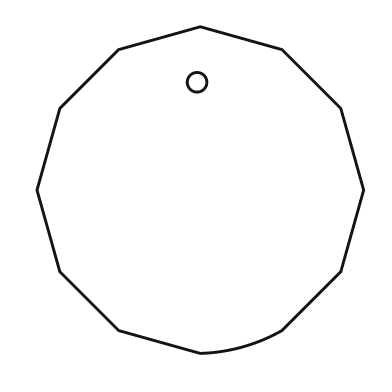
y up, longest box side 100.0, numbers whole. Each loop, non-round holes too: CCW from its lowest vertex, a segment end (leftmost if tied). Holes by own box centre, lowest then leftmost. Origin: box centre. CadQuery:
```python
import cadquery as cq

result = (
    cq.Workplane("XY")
    .moveTo(0.0, -50.0)
    .threePointArc((13.0, -48.0), (25.0, -43.0))
    .lineTo(43.0, -25.0)
    .lineTo(50.0, 0.0)
    .lineTo(43.0, 25.0)
    .lineTo(25.0, 43.0)
    .lineTo(0.0, 50.0)
    .lineTo(-25.0, 43.0)
    .lineTo(-43.0, 25.0)
    .lineTo(-50.0, 0.0)
    .lineTo(-43.0, -25.0)
    .lineTo(-25.0, -43.0)
    .close()
    .moveTo(-1.0, 33.0)
    .circle(3.0)
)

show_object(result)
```